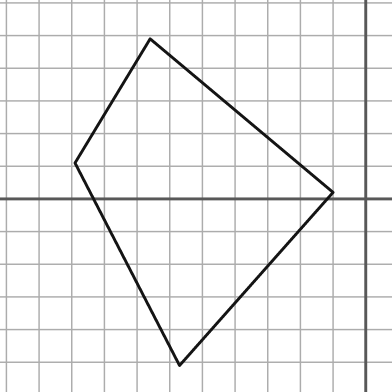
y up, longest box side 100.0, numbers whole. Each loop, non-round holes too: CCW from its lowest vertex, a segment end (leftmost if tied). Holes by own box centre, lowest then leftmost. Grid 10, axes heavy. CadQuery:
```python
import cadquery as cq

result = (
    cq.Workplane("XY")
    .moveTo(-57.0, -51.0)
    .lineTo(-10.0, 2.0)
    .lineTo(-66.0, 49.0)
    .lineTo(-89.0, 11.0)
    .close()
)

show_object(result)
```